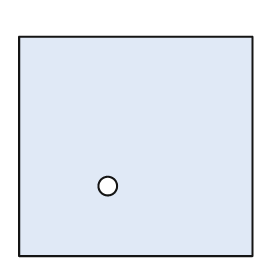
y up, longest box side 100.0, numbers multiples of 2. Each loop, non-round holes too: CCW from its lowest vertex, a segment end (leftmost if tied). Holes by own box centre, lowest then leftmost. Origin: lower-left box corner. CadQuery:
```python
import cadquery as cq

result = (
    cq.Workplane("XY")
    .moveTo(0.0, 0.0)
    .lineTo(100.0, 0.0)
    .lineTo(100.0, 94.0)
    .lineTo(0.0, 94.0)
    .close()
    .moveTo(38.0, 30.0)
    .circle(4.0)
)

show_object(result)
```